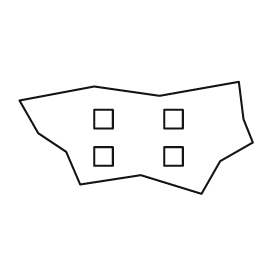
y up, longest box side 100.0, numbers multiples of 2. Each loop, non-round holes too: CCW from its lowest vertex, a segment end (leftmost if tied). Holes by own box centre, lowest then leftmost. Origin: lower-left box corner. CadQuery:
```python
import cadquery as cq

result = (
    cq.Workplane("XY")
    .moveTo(78.0, 0.0)
    .lineTo(86.0, 14.0)
    .lineTo(100.0, 22.0)
    .lineTo(96.0, 32.0)
    .lineTo(94.0, 48.0)
    .lineTo(60.0, 42.0)
    .lineTo(32.0, 46.0)
    .lineTo(0.0, 40.0)
    .lineTo(8.0, 26.0)
    .lineTo(20.0, 18.0)
    .lineTo(26.0, 4.0)
    .lineTo(52.0, 8.0)
    .close()
    .moveTo(32.0, 12.0)
    .lineTo(40.0, 12.0)
    .lineTo(40.0, 20.0)
    .lineTo(32.0, 20.0)
    .close()
    .moveTo(62.0, 12.0)
    .lineTo(70.0, 12.0)
    .lineTo(70.0, 20.0)
    .lineTo(62.0, 20.0)
    .close()
    .moveTo(32.0, 28.0)
    .lineTo(40.0, 28.0)
    .lineTo(40.0, 36.0)
    .lineTo(32.0, 36.0)
    .close()
    .moveTo(62.0, 28.0)
    .lineTo(70.0, 28.0)
    .lineTo(70.0, 36.0)
    .lineTo(62.0, 36.0)
    .close()
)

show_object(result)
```